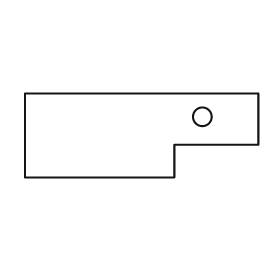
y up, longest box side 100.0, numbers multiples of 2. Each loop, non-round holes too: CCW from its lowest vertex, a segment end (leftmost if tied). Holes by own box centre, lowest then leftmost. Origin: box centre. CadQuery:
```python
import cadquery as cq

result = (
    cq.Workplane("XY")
    .moveTo(-50.0, -18.0)
    .lineTo(14.0, -18.0)
    .lineTo(14.0, -4.0)
    .lineTo(50.0, -4.0)
    .lineTo(50.0, 18.0)
    .lineTo(-50.0, 18.0)
    .close()
    .moveTo(26.0, 8.0)
    .circle(4.0)
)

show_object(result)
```